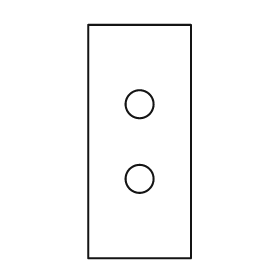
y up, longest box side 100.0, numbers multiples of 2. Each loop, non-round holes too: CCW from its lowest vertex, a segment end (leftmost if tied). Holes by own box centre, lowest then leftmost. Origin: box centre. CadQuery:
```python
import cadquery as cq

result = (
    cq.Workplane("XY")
    .moveTo(-22.0, -50.0)
    .lineTo(22.0, -50.0)
    .lineTo(22.0, 50.0)
    .lineTo(-22.0, 50.0)
    .close()
    .moveTo(0.0, -16.0)
    .circle(6.0)
    .moveTo(0.0, 16.0)
    .circle(6.0)
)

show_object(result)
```